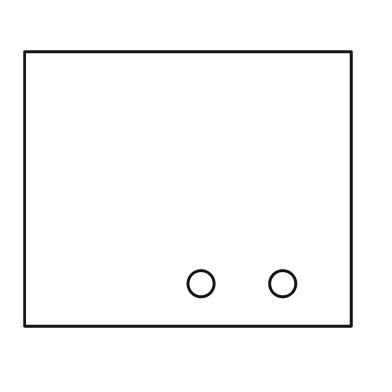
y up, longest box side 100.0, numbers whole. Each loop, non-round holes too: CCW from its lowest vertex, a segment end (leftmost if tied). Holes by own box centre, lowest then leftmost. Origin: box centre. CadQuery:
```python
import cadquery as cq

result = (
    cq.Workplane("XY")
    .moveTo(-50.0, -42.0)
    .lineTo(50.0, -42.0)
    .lineTo(50.0, 42.0)
    .lineTo(-50.0, 42.0)
    .close()
    .moveTo(4.0, -29.0)
    .circle(4.0)
    .moveTo(29.0, -29.0)
    .circle(4.0)
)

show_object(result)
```